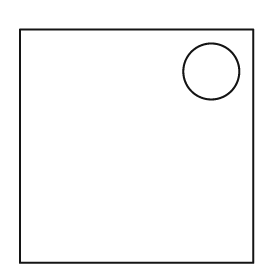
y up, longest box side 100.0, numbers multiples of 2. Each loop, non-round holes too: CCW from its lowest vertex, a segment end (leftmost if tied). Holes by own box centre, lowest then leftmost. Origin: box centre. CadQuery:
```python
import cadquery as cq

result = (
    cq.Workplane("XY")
    .moveTo(-50.0, -50.0)
    .lineTo(50.0, -50.0)
    .lineTo(50.0, 50.0)
    .lineTo(-50.0, 50.0)
    .close()
    .moveTo(32.0, 32.0)
    .circle(12.0)
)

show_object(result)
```